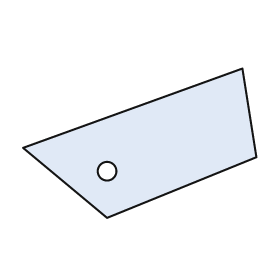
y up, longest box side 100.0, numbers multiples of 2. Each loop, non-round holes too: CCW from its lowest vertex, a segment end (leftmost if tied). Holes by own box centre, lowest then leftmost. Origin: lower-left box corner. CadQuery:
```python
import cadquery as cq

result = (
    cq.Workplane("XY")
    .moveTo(36.0, 0.0)
    .lineTo(100.0, 26.0)
    .lineTo(94.0, 64.0)
    .lineTo(0.0, 30.0)
    .close()
    .moveTo(36.0, 20.0)
    .circle(4.0)
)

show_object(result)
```